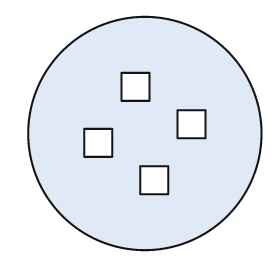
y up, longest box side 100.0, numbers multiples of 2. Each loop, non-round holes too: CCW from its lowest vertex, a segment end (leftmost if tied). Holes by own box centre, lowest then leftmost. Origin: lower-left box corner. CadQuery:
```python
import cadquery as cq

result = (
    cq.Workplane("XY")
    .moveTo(50.0, 50.0)
    .circle(50.0)
    .moveTo(48.0, 24.0)
    .lineTo(60.0, 24.0)
    .lineTo(60.0, 36.0)
    .lineTo(48.0, 36.0)
    .close()
    .moveTo(24.0, 40.0)
    .lineTo(36.0, 40.0)
    .lineTo(36.0, 52.0)
    .lineTo(24.0, 52.0)
    .close()
    .moveTo(64.0, 48.0)
    .lineTo(76.0, 48.0)
    .lineTo(76.0, 60.0)
    .lineTo(64.0, 60.0)
    .close()
    .moveTo(40.0, 64.0)
    .lineTo(52.0, 64.0)
    .lineTo(52.0, 76.0)
    .lineTo(40.0, 76.0)
    .close()
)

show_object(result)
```